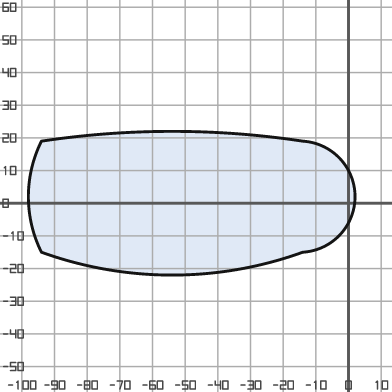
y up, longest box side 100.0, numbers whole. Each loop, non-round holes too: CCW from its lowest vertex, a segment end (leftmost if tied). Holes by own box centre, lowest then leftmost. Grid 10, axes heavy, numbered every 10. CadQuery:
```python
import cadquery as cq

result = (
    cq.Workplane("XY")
    .moveTo(-94.0, -15.0)
    .threePointArc((-54.0, -22.0), (-14.0, -15.0))
    .threePointArc((2.0, 2.0), (-14.0, 19.0))
    .threePointArc((-54.0, 22.0), (-94.0, 19.0))
    .threePointArc((-98.0, 2.0), (-94.0, -15.0))
    .close()
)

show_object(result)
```